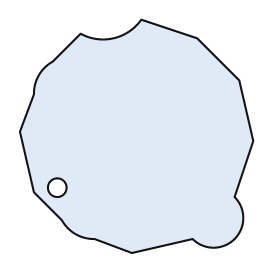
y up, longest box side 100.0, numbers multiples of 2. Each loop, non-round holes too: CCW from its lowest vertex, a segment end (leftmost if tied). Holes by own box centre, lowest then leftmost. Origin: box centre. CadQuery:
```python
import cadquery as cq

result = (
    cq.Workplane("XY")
    .moveTo(-2.0, -50.0)
    .lineTo(24.0, -44.0)
    .threePointArc((42.0, -44.0), (42.0, -26.0))
    .lineTo(50.0, -2.0)
    .lineTo(44.0, 24.0)
    .lineTo(26.0, 42.0)
    .lineTo(2.0, 50.0)
    .threePointArc((-10.0, 42.0), (-24.0, 44.0))
    .lineTo(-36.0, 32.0)
    .threePointArc((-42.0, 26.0), (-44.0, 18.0))
    .lineTo(-50.0, 2.0)
    .lineTo(-44.0, -24.0)
    .lineTo(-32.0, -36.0)
    .threePointArc((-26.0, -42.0), (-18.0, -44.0))
    .close()
    .moveTo(-34.0, -22.0)
    .circle(4.0)
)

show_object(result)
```